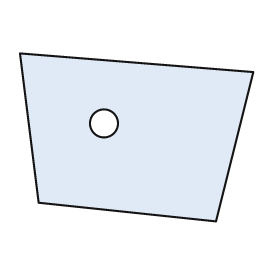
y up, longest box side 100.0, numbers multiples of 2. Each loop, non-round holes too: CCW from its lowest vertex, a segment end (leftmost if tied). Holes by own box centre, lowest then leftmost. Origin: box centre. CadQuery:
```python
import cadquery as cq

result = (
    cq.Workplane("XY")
    .moveTo(34.0, -36.0)
    .lineTo(50.0, 28.0)
    .lineTo(-50.0, 36.0)
    .lineTo(-42.0, -28.0)
    .close()
    .moveTo(-14.0, 6.0)
    .circle(6.0)
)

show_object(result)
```